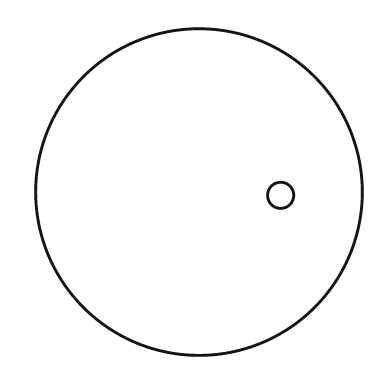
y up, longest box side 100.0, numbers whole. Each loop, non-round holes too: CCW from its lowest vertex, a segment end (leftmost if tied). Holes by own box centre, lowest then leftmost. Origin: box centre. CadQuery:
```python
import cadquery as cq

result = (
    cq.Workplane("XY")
    .moveTo(0.0, 0.0)
    .circle(50.0)
    .moveTo(25.0, -1.0)
    .circle(4.0)
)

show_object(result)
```